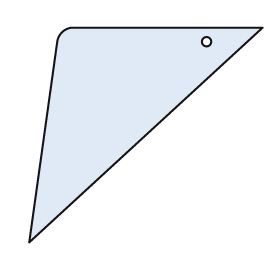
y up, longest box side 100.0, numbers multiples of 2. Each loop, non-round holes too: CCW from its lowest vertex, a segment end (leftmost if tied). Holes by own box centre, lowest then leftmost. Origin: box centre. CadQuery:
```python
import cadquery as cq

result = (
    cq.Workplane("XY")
    .moveTo(-50.0, -46.0)
    .lineTo(50.0, 46.0)
    .lineTo(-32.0, 46.0)
    .threePointArc((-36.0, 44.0), (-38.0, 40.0))
    .close()
    .moveTo(26.0, 40.0)
    .circle(2.0)
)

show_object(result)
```